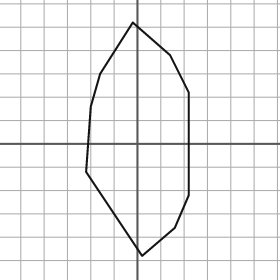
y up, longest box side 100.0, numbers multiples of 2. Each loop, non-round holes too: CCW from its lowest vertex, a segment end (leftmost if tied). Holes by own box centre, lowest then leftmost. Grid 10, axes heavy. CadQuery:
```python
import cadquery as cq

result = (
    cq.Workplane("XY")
    .moveTo(2.0, -48.0)
    .lineTo(16.0, -36.0)
    .lineTo(22.0, -22.0)
    .lineTo(22.0, 22.0)
    .lineTo(14.0, 38.0)
    .lineTo(-2.0, 52.0)
    .lineTo(-16.0, 30.0)
    .lineTo(-20.0, 16.0)
    .lineTo(-22.0, -12.0)
    .close()
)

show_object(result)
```